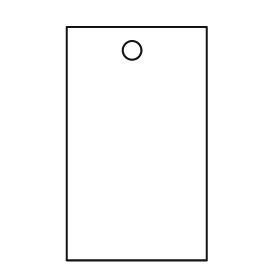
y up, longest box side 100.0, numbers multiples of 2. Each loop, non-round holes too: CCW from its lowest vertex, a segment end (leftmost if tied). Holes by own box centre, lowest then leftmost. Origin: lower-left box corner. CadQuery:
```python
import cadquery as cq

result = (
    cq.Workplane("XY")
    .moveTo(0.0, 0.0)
    .lineTo(60.0, 0.0)
    .lineTo(60.0, 100.0)
    .lineTo(0.0, 100.0)
    .close()
    .moveTo(28.0, 90.0)
    .circle(4.0)
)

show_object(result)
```